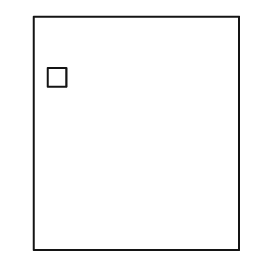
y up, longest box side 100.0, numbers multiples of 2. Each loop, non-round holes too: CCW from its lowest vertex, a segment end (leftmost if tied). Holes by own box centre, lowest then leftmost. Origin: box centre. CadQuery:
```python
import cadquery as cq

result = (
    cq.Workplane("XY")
    .moveTo(-44.0, -50.0)
    .lineTo(44.0, -50.0)
    .lineTo(44.0, 50.0)
    .lineTo(-44.0, 50.0)
    .close()
    .moveTo(-38.0, 20.0)
    .lineTo(-30.0, 20.0)
    .lineTo(-30.0, 28.0)
    .lineTo(-38.0, 28.0)
    .close()
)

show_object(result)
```